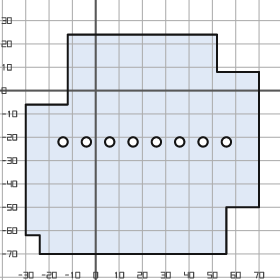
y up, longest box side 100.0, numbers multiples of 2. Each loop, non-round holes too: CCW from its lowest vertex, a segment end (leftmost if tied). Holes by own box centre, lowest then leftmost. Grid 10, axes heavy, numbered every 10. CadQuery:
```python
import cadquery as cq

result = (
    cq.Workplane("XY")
    .moveTo(-24.0, -70.0)
    .lineTo(56.0, -70.0)
    .lineTo(56.0, -50.0)
    .lineTo(70.0, -50.0)
    .lineTo(70.0, 8.0)
    .lineTo(52.0, 8.0)
    .lineTo(52.0, 24.0)
    .lineTo(-12.0, 24.0)
    .lineTo(-12.0, -6.0)
    .lineTo(-30.0, -6.0)
    .lineTo(-30.0, -62.0)
    .lineTo(-24.0, -62.0)
    .close()
    .moveTo(-14.0, -22.0)
    .circle(2.0)
    .moveTo(-4.0, -22.0)
    .circle(2.0)
    .moveTo(6.0, -22.0)
    .circle(2.0)
    .moveTo(16.0, -22.0)
    .circle(2.0)
    .moveTo(26.0, -22.0)
    .circle(2.0)
    .moveTo(36.0, -22.0)
    .circle(2.0)
    .moveTo(46.0, -22.0)
    .circle(2.0)
    .moveTo(56.0, -22.0)
    .circle(2.0)
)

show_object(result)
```